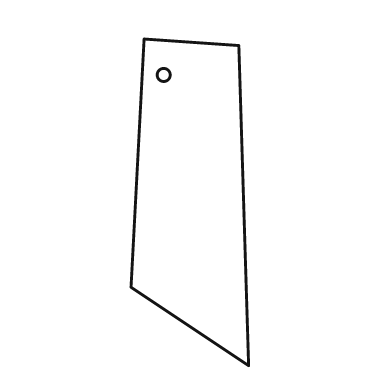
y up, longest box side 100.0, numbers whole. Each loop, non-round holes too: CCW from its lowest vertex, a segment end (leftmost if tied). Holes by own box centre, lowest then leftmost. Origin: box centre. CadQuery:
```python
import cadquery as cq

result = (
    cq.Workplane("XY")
    .moveTo(18.0, -50.0)
    .lineTo(15.0, 48.0)
    .lineTo(-14.0, 50.0)
    .lineTo(-18.0, -26.0)
    .close()
    .moveTo(-8.0, 39.0)
    .circle(2.0)
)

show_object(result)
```